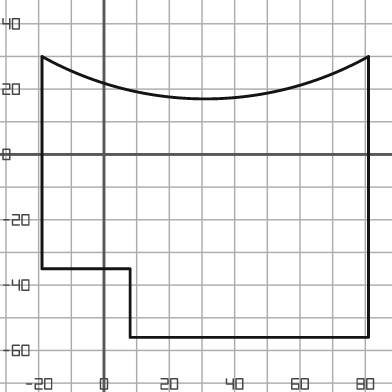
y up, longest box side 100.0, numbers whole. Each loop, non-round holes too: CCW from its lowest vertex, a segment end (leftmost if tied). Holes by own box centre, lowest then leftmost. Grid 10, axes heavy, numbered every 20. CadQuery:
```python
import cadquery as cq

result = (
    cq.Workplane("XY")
    .moveTo(8.0, -56.0)
    .lineTo(81.0, -56.0)
    .lineTo(81.0, 30.0)
    .threePointArc((31.0, 17.0), (-19.0, 30.0))
    .lineTo(-19.0, -35.0)
    .lineTo(8.0, -35.0)
    .close()
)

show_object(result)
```